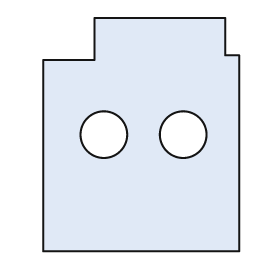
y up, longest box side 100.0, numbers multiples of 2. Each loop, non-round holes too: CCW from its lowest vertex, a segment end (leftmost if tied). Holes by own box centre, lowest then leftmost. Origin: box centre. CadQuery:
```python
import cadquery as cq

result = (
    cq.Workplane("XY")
    .moveTo(-42.0, -50.0)
    .lineTo(42.0, -50.0)
    .lineTo(42.0, 34.0)
    .lineTo(36.0, 34.0)
    .lineTo(36.0, 50.0)
    .lineTo(-20.0, 50.0)
    .lineTo(-20.0, 32.0)
    .lineTo(-42.0, 32.0)
    .close()
    .moveTo(-16.0, 0.0)
    .circle(10.0)
    .moveTo(18.0, 0.0)
    .circle(10.0)
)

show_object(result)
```